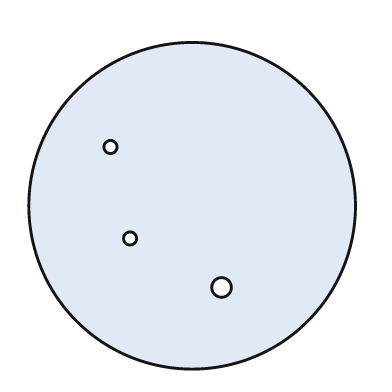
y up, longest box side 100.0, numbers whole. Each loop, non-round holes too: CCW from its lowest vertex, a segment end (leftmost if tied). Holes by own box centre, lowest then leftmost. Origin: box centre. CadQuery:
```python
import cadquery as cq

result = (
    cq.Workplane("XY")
    .moveTo(0.0, 0.0)
    .circle(50.0)
    .moveTo(9.0, -25.0)
    .circle(3.0)
    .moveTo(-19.0, -10.0)
    .circle(2.0)
    .moveTo(-25.0, 18.0)
    .circle(2.0)
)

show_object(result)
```